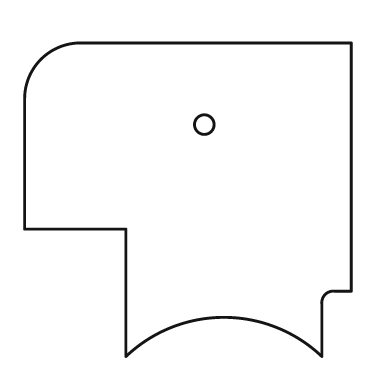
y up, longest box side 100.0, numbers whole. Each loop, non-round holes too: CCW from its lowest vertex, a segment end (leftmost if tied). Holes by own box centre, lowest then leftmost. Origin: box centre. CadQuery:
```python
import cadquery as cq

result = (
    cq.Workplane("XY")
    .moveTo(-19.0, -48.0)
    .threePointArc((11.0, -36.0), (41.0, -48.0))
    .lineTo(41.0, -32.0)
    .threePointArc((42.0, -29.0), (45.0, -28.0))
    .lineTo(50.0, -28.0)
    .lineTo(50.0, 48.0)
    .lineTo(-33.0, 48.0)
    .threePointArc((-45.0, 43.0), (-50.0, 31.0))
    .lineTo(-50.0, -9.0)
    .lineTo(-19.0, -9.0)
    .close()
    .moveTo(5.0, 23.0)
    .circle(3.0)
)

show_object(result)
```